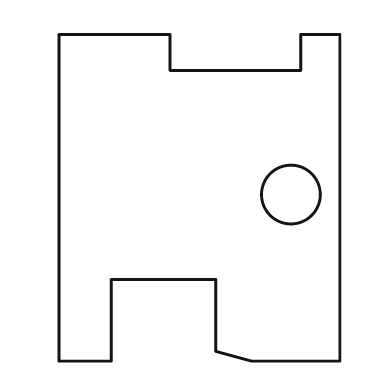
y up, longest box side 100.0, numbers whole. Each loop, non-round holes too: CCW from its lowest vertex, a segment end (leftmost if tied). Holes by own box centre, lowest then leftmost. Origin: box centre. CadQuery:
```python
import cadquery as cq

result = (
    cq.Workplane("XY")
    .moveTo(-43.0, -50.0)
    .lineTo(-27.0, -50.0)
    .lineTo(-27.0, -25.0)
    .lineTo(5.0, -25.0)
    .lineTo(5.0, -47.0)
    .lineTo(16.0, -50.0)
    .lineTo(43.0, -50.0)
    .lineTo(43.0, 50.0)
    .lineTo(31.0, 50.0)
    .lineTo(31.0, 39.0)
    .lineTo(-9.0, 39.0)
    .lineTo(-9.0, 50.0)
    .lineTo(-43.0, 50.0)
    .close()
    .moveTo(28.0, 1.0)
    .circle(9.0)
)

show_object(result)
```